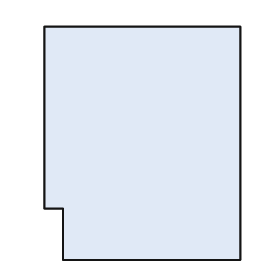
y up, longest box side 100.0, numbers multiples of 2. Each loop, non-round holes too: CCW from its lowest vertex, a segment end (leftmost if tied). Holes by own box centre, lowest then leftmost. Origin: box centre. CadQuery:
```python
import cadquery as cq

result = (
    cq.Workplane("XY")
    .moveTo(-34.0, -50.0)
    .lineTo(42.0, -50.0)
    .lineTo(42.0, 50.0)
    .lineTo(-42.0, 50.0)
    .lineTo(-42.0, -28.0)
    .lineTo(-34.0, -28.0)
    .close()
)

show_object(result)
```